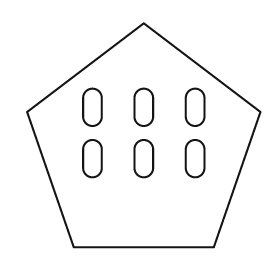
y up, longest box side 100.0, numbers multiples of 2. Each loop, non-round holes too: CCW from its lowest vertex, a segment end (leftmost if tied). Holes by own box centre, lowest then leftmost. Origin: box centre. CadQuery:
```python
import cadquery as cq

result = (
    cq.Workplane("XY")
    .moveTo(-30.0, -48.0)
    .lineTo(30.0, -48.0)
    .lineTo(50.0, 10.0)
    .lineTo(0.0, 48.0)
    .lineTo(-50.0, 10.0)
    .close()
    .moveTo(-26.0, -14.0)
    .threePointArc((-22.0, -18.0), (-18.0, -14.0))
    .lineTo(-18.0, -6.0)
    .threePointArc((-22.0, -2.0), (-26.0, -6.0))
    .close()
    .moveTo(-4.0, -14.0)
    .threePointArc((0.0, -18.0), (4.0, -14.0))
    .lineTo(4.0, -6.0)
    .threePointArc((0.0, -2.0), (-4.0, -6.0))
    .close()
    .moveTo(18.0, -14.0)
    .threePointArc((22.0, -18.0), (26.0, -14.0))
    .lineTo(26.0, -6.0)
    .threePointArc((22.0, -2.0), (18.0, -6.0))
    .close()
    .moveTo(-26.0, 8.0)
    .threePointArc((-22.0, 4.0), (-18.0, 8.0))
    .lineTo(-18.0, 16.0)
    .threePointArc((-22.0, 20.0), (-26.0, 16.0))
    .close()
    .moveTo(-4.0, 8.0)
    .threePointArc((0.0, 4.0), (4.0, 8.0))
    .lineTo(4.0, 16.0)
    .threePointArc((0.0, 20.0), (-4.0, 16.0))
    .close()
    .moveTo(18.0, 8.0)
    .threePointArc((22.0, 4.0), (26.0, 8.0))
    .lineTo(26.0, 16.0)
    .threePointArc((22.0, 20.0), (18.0, 16.0))
    .close()
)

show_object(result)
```